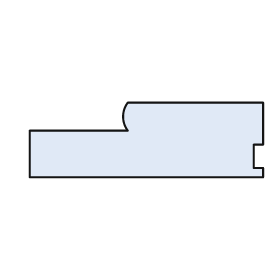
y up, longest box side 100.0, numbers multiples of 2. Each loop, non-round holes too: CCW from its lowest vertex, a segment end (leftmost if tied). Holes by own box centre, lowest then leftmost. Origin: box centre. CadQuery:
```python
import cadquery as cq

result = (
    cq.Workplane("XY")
    .moveTo(-50.0, -16.0)
    .lineTo(50.0, -16.0)
    .lineTo(50.0, -12.0)
    .lineTo(46.0, -12.0)
    .lineTo(46.0, -2.0)
    .lineTo(50.0, -2.0)
    .lineTo(50.0, 16.0)
    .lineTo(-8.0, 16.0)
    .threePointArc((-10.0, 10.0), (-8.0, 4.0))
    .lineTo(-50.0, 4.0)
    .close()
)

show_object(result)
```